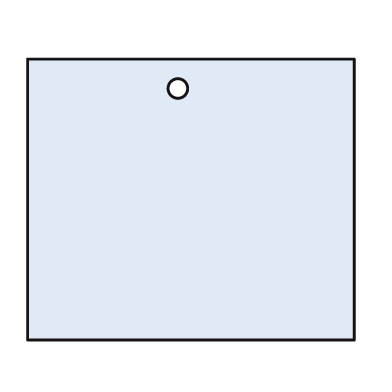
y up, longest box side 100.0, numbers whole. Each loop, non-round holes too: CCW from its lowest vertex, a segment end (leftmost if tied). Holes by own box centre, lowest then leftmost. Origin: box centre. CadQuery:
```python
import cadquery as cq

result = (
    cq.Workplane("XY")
    .moveTo(-50.0, -43.0)
    .lineTo(50.0, -43.0)
    .lineTo(50.0, 43.0)
    .lineTo(-50.0, 43.0)
    .close()
    .moveTo(-4.0, 34.0)
    .circle(3.0)
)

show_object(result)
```